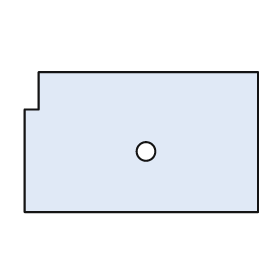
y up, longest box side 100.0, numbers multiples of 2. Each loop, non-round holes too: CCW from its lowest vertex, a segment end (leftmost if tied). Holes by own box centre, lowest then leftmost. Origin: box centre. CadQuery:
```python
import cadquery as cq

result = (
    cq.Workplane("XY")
    .moveTo(-50.0, -30.0)
    .lineTo(50.0, -30.0)
    .lineTo(50.0, 30.0)
    .lineTo(-44.0, 30.0)
    .lineTo(-44.0, 14.0)
    .lineTo(-50.0, 14.0)
    .close()
    .moveTo(2.0, -4.0)
    .circle(4.0)
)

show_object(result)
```